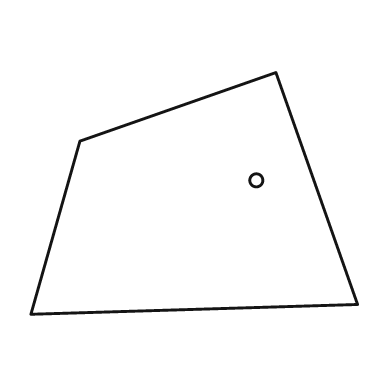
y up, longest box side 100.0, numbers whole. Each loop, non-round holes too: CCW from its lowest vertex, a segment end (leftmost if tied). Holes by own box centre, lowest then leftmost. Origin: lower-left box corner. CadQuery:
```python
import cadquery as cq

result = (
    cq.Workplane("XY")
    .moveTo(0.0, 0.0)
    .lineTo(100.0, 3.0)
    .lineTo(75.0, 74.0)
    .lineTo(15.0, 53.0)
    .close()
    .moveTo(69.0, 41.0)
    .circle(2.0)
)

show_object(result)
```